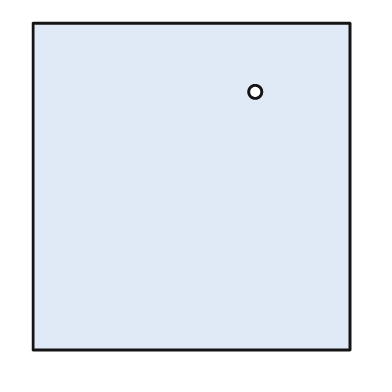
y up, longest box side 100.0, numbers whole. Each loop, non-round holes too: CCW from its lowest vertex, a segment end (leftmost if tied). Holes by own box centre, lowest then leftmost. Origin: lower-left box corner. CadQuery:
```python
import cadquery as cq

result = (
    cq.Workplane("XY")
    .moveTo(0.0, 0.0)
    .lineTo(97.0, 0.0)
    .lineTo(97.0, 100.0)
    .lineTo(0.0, 100.0)
    .close()
    .moveTo(68.0, 79.0)
    .circle(2.0)
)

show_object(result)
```